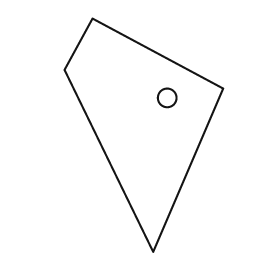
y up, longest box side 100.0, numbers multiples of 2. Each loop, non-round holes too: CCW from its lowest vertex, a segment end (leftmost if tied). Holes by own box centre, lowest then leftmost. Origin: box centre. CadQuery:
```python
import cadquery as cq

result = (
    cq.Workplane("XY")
    .moveTo(4.0, -50.0)
    .lineTo(34.0, 20.0)
    .lineTo(-22.0, 50.0)
    .lineTo(-34.0, 28.0)
    .close()
    .moveTo(10.0, 16.0)
    .circle(4.0)
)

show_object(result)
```